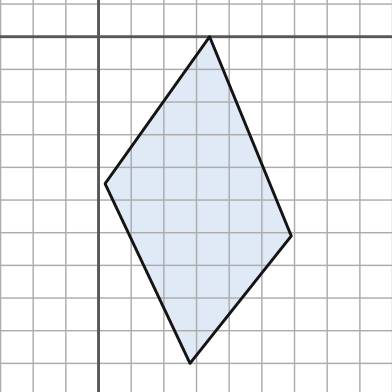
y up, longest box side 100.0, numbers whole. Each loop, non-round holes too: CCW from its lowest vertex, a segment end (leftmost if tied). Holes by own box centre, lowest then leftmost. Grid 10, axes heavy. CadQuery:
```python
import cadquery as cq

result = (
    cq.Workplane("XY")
    .moveTo(28.0, -100.0)
    .lineTo(59.0, -61.0)
    .lineTo(34.0, 0.0)
    .lineTo(2.0, -45.0)
    .close()
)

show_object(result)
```